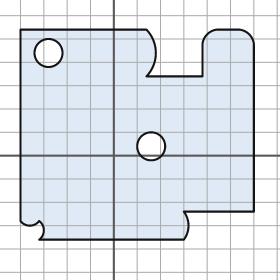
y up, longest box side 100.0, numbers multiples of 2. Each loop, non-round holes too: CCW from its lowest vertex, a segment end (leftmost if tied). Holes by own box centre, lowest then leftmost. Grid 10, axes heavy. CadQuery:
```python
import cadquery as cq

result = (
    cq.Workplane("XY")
    .moveTo(-32.0, -36.0)
    .lineTo(30.0, -36.0)
    .threePointArc((32.0, -30.0), (30.0, -24.0))
    .lineTo(60.0, -24.0)
    .lineTo(60.0, 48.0)
    .threePointArc((58.0, 52.0), (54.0, 54.0))
    .lineTo(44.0, 54.0)
    .threePointArc((40.0, 52.0), (38.0, 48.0))
    .lineTo(38.0, 34.0)
    .lineTo(14.0, 34.0)
    .threePointArc((18.0, 44.0), (14.0, 54.0))
    .lineTo(-40.0, 54.0)
    .lineTo(-40.0, -28.0)
    .threePointArc((-36.0, -30.0), (-32.0, -28.0))
    .threePointArc((-30.0, -32.0), (-32.0, -36.0))
    .close()
    .moveTo(16.0, 4.0)
    .circle(6.0)
    .moveTo(-28.0, 44.0)
    .circle(6.0)
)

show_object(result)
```